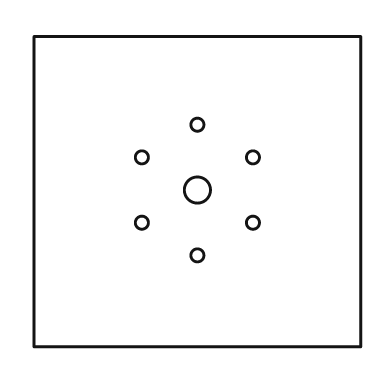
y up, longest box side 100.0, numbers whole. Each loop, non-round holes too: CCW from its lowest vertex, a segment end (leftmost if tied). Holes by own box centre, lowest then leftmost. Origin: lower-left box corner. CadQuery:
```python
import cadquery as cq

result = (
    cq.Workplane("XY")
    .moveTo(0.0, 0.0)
    .lineTo(100.0, 0.0)
    .lineTo(100.0, 95.0)
    .lineTo(0.0, 95.0)
    .close()
    .moveTo(50.0, 28.0)
    .circle(2.0)
    .moveTo(33.0, 38.0)
    .circle(2.0)
    .moveTo(67.0, 38.0)
    .circle(2.0)
    .moveTo(50.0, 48.0)
    .circle(4.0)
    .moveTo(33.0, 58.0)
    .circle(2.0)
    .moveTo(67.0, 58.0)
    .circle(2.0)
    .moveTo(50.0, 68.0)
    .circle(2.0)
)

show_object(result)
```